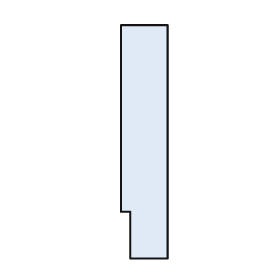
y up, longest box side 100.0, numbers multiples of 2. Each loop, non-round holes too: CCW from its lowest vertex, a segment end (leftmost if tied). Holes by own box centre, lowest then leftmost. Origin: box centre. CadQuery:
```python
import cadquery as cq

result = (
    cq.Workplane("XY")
    .moveTo(-6.0, -50.0)
    .lineTo(10.0, -50.0)
    .lineTo(10.0, 50.0)
    .lineTo(-10.0, 50.0)
    .lineTo(-10.0, -30.0)
    .lineTo(-6.0, -30.0)
    .close()
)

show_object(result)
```